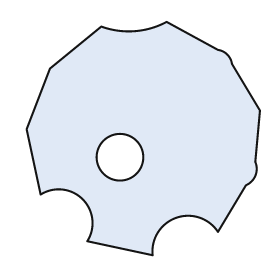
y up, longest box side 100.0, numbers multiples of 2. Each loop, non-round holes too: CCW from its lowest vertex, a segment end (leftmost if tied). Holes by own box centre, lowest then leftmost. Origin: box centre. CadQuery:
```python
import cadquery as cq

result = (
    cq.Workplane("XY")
    .moveTo(4.0, -50.0)
    .threePointArc((14.0, -34.0), (32.0, -40.0))
    .lineTo(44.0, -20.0)
    .threePointArc((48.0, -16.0), (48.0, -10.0))
    .lineTo(50.0, 12.0)
    .lineTo(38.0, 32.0)
    .threePointArc((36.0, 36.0), (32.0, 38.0))
    .lineTo(10.0, 50.0)
    .threePointArc((-4.0, 46.0), (-18.0, 48.0))
    .lineTo(-40.0, 30.0)
    .lineTo(-50.0, 4.0)
    .lineTo(-44.0, -24.0)
    .threePointArc((-26.0, -26.0), (-24.0, -44.0))
    .close()
    .moveTo(-10.0, -8.0)
    .circle(10.0)
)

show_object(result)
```